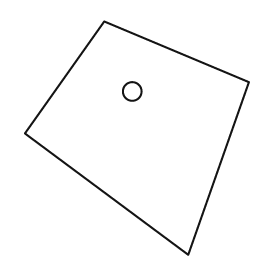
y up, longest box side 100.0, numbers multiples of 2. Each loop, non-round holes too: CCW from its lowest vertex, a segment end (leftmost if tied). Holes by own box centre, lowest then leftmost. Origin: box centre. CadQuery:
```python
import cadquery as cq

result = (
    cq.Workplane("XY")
    .moveTo(22.0, -50.0)
    .lineTo(48.0, 24.0)
    .lineTo(-14.0, 50.0)
    .lineTo(-48.0, 2.0)
    .close()
    .moveTo(-2.0, 20.0)
    .circle(4.0)
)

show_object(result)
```